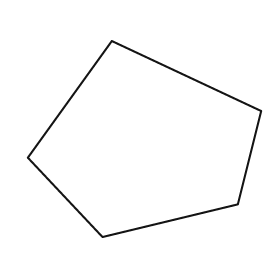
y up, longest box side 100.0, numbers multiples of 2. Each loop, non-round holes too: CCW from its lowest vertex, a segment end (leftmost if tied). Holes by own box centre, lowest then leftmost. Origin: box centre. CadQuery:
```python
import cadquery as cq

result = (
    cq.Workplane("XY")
    .moveTo(-18.0, -42.0)
    .lineTo(40.0, -28.0)
    .lineTo(50.0, 12.0)
    .lineTo(-14.0, 42.0)
    .lineTo(-50.0, -8.0)
    .close()
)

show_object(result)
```